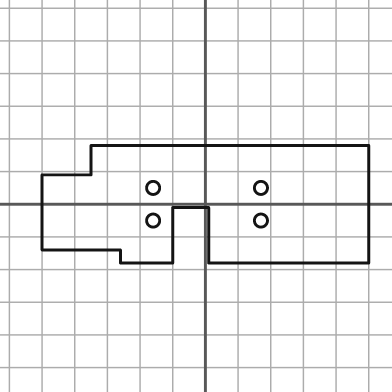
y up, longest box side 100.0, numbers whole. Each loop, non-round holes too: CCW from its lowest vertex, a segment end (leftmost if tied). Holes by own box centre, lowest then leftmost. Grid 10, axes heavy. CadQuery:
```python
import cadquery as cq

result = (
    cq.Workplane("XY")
    .moveTo(-26.0, -18.0)
    .lineTo(-10.0, -18.0)
    .lineTo(-10.0, -1.0)
    .lineTo(1.0, -1.0)
    .lineTo(1.0, -18.0)
    .lineTo(50.0, -18.0)
    .lineTo(50.0, 18.0)
    .lineTo(-35.0, 18.0)
    .lineTo(-35.0, 9.0)
    .lineTo(-50.0, 9.0)
    .lineTo(-50.0, -14.0)
    .lineTo(-26.0, -14.0)
    .close()
    .moveTo(-16.0, -5.0)
    .circle(2.0)
    .moveTo(17.0, -5.0)
    .circle(2.0)
    .moveTo(-16.0, 5.0)
    .circle(2.0)
    .moveTo(17.0, 5.0)
    .circle(2.0)
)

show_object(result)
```